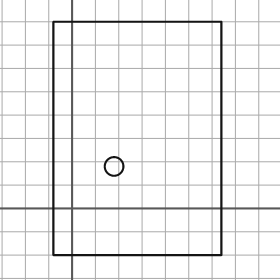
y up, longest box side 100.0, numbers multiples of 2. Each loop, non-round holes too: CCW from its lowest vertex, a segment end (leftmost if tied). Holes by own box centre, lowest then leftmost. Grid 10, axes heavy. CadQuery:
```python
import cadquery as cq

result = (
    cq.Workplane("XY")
    .moveTo(-8.0, -20.0)
    .lineTo(64.0, -20.0)
    .lineTo(64.0, 80.0)
    .lineTo(-8.0, 80.0)
    .close()
    .moveTo(18.0, 18.0)
    .circle(4.0)
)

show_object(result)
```